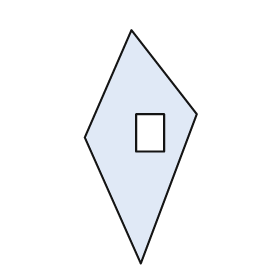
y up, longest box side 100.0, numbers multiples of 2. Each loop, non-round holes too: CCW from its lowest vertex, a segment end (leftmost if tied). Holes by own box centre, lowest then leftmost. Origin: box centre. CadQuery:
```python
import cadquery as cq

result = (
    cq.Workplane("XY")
    .moveTo(0.0, -50.0)
    .lineTo(24.0, 14.0)
    .lineTo(-4.0, 50.0)
    .lineTo(-24.0, 4.0)
    .close()
    .moveTo(-2.0, -2.0)
    .lineTo(10.0, -2.0)
    .lineTo(10.0, 14.0)
    .lineTo(-2.0, 14.0)
    .close()
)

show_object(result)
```